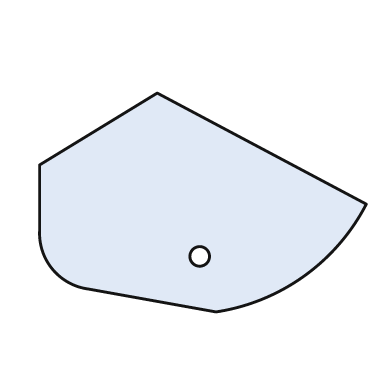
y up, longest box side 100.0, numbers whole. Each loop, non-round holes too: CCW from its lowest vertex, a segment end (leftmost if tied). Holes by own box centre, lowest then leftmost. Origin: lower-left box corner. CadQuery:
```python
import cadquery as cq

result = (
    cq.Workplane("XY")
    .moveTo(54.0, 0.0)
    .threePointArc((81.0, 11.0), (100.0, 33.0))
    .lineTo(36.0, 67.0)
    .lineTo(0.0, 45.0)
    .lineTo(0.0, 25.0)
    .threePointArc((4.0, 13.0), (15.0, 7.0))
    .close()
    .moveTo(49.0, 17.0)
    .circle(3.0)
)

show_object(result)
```